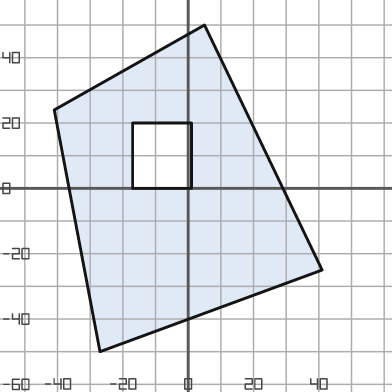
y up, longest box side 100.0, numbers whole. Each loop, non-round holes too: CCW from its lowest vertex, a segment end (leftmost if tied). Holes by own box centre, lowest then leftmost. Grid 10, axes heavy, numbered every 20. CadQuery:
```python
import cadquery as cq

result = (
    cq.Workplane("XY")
    .moveTo(-27.0, -50.0)
    .lineTo(41.0, -25.0)
    .lineTo(5.0, 50.0)
    .lineTo(-41.0, 24.0)
    .close()
    .moveTo(-17.0, 0.0)
    .lineTo(1.0, 0.0)
    .lineTo(1.0, 20.0)
    .lineTo(-17.0, 20.0)
    .close()
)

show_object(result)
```